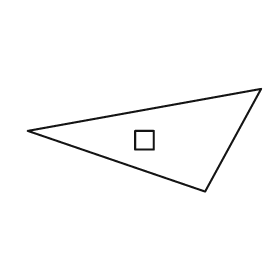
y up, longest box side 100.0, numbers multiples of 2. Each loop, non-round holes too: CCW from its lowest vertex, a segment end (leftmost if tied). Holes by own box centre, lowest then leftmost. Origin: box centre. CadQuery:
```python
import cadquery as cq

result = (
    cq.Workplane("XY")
    .moveTo(26.0, -22.0)
    .lineTo(50.0, 22.0)
    .lineTo(-50.0, 4.0)
    .close()
    .moveTo(-4.0, -4.0)
    .lineTo(4.0, -4.0)
    .lineTo(4.0, 4.0)
    .lineTo(-4.0, 4.0)
    .close()
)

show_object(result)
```